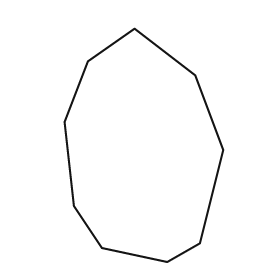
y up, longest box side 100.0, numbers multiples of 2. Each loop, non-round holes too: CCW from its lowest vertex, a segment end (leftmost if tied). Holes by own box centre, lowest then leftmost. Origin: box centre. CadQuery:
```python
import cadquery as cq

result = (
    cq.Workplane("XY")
    .moveTo(10.0, -50.0)
    .lineTo(24.0, -42.0)
    .lineTo(34.0, -2.0)
    .lineTo(22.0, 30.0)
    .lineTo(-4.0, 50.0)
    .lineTo(-24.0, 36.0)
    .lineTo(-34.0, 10.0)
    .lineTo(-30.0, -26.0)
    .lineTo(-18.0, -44.0)
    .close()
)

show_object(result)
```